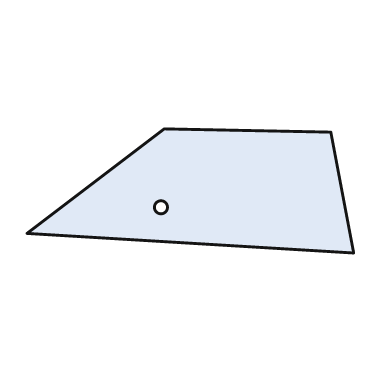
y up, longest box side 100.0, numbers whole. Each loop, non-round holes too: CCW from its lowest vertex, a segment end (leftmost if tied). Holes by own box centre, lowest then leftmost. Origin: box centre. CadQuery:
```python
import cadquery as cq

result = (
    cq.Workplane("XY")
    .moveTo(50.0, -19.0)
    .lineTo(43.0, 18.0)
    .lineTo(-8.0, 19.0)
    .lineTo(-50.0, -13.0)
    .close()
    .moveTo(-9.0, -5.0)
    .circle(2.0)
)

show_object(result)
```